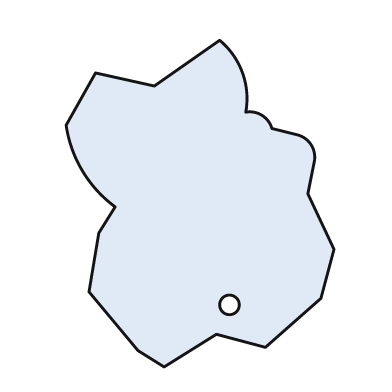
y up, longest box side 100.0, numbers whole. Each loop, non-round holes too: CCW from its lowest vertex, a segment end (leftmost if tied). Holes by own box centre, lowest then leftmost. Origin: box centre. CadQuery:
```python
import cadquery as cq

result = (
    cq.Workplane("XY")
    .moveTo(-11.0, -50.0)
    .lineTo(5.0, -40.0)
    .lineTo(20.0, -44.0)
    .lineTo(37.0, -29.0)
    .lineTo(41.0, -14.0)
    .lineTo(33.0, 3.0)
    .lineTo(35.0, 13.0)
    .threePointArc((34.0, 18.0), (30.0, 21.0))
    .lineTo(22.0, 23.0)
    .threePointArc((19.0, 27.0), (14.0, 28.0))
    .threePointArc((13.0, 40.0), (6.0, 50.0))
    .lineTo(-14.0, 36.0)
    .lineTo(-32.0, 40.0)
    .lineTo(-41.0, 24.0)
    .threePointArc((-36.0, 10.0), (-26.0, -1.0))
    .lineTo(-31.0, -9.0)
    .lineTo(-34.0, -27.0)
    .lineTo(-19.0, -45.0)
    .close()
    .moveTo(9.0, -31.0)
    .circle(3.0)
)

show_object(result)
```